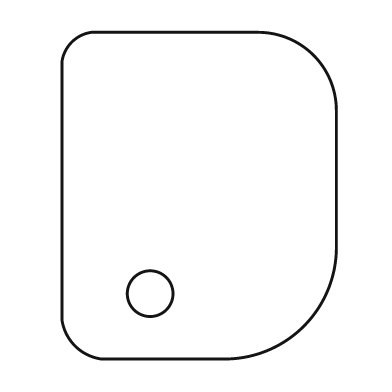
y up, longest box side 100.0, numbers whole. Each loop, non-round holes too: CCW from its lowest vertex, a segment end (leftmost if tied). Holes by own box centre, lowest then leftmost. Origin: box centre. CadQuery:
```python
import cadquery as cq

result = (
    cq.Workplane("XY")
    .moveTo(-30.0, -50.0)
    .lineTo(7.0, -50.0)
    .threePointArc((32.0, -40.0), (42.0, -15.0))
    .lineTo(42.0, 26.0)
    .threePointArc((35.0, 43.0), (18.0, 50.0))
    .lineTo(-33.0, 50.0)
    .threePointArc((-39.0, 47.0), (-42.0, 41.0))
    .lineTo(-42.0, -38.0)
    .threePointArc((-38.0, -46.0), (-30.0, -50.0))
    .close()
    .moveTo(-15.0, -30.0)
    .circle(7.0)
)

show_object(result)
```